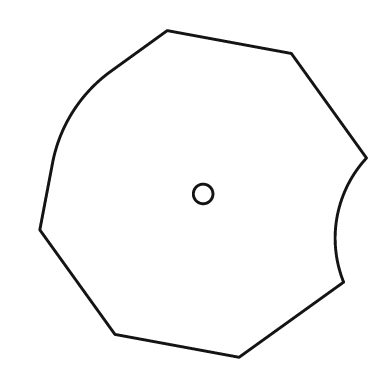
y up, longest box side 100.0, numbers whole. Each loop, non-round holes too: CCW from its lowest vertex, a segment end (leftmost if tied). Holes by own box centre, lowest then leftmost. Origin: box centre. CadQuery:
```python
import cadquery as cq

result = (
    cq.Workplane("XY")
    .moveTo(11.0, -50.0)
    .lineTo(43.0, -27.0)
    .threePointArc((41.0, -7.0), (50.0, 11.0))
    .lineTo(27.0, 43.0)
    .lineTo(-11.0, 50.0)
    .lineTo(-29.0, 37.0)
    .threePointArc((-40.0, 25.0), (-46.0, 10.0))
    .lineTo(-50.0, -11.0)
    .lineTo(-27.0, -43.0)
    .close()
    .moveTo(0.0, 0.0)
    .circle(3.0)
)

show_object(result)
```